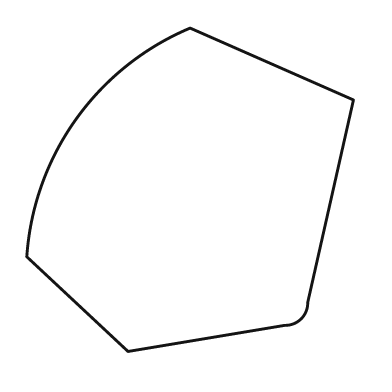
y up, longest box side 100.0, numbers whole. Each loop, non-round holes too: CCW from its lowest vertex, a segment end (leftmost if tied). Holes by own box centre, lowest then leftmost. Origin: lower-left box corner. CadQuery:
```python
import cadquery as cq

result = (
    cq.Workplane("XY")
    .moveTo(31.0, 0.0)
    .lineTo(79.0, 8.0)
    .threePointArc((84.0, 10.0), (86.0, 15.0))
    .lineTo(100.0, 77.0)
    .lineTo(50.0, 99.0)
    .threePointArc((15.0, 71.0), (0.0, 29.0))
    .close()
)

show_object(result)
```